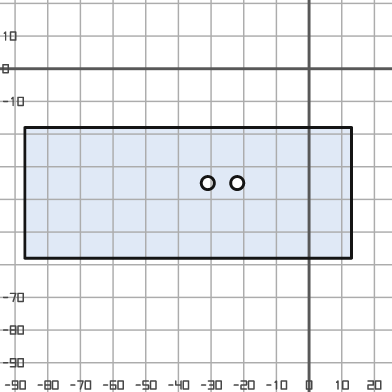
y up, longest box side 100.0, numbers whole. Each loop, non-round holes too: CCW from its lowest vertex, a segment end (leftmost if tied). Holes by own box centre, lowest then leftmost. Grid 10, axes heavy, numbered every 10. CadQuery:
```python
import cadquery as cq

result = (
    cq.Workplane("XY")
    .moveTo(-87.0, -58.0)
    .lineTo(13.0, -58.0)
    .lineTo(13.0, -18.0)
    .lineTo(-87.0, -18.0)
    .close()
    .moveTo(-31.0, -35.0)
    .circle(2.0)
    .moveTo(-22.0, -35.0)
    .circle(2.0)
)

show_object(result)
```